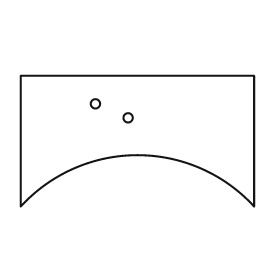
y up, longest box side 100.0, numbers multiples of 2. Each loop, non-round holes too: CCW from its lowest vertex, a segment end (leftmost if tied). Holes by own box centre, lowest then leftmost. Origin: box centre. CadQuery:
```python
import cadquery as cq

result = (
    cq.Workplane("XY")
    .moveTo(-50.0, -28.0)
    .threePointArc((0.0, -6.0), (50.0, -28.0))
    .lineTo(50.0, 28.0)
    .lineTo(-50.0, 28.0)
    .close()
    .moveTo(-4.0, 10.0)
    .circle(2.0)
    .moveTo(-18.0, 16.0)
    .circle(2.0)
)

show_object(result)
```